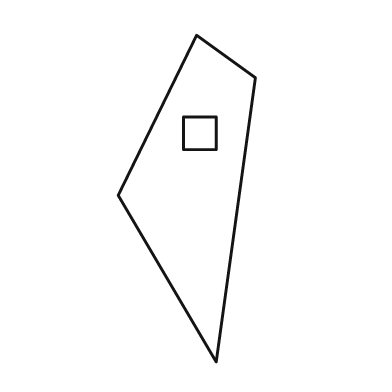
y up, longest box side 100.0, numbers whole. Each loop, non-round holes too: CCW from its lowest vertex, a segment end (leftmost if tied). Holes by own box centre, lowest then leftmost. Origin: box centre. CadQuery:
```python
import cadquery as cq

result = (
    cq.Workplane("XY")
    .moveTo(9.0, -50.0)
    .lineTo(21.0, 37.0)
    .lineTo(3.0, 50.0)
    .lineTo(-21.0, 1.0)
    .close()
    .moveTo(-1.0, 15.0)
    .lineTo(9.0, 15.0)
    .lineTo(9.0, 25.0)
    .lineTo(-1.0, 25.0)
    .close()
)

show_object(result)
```